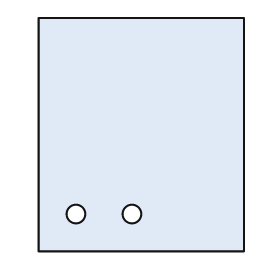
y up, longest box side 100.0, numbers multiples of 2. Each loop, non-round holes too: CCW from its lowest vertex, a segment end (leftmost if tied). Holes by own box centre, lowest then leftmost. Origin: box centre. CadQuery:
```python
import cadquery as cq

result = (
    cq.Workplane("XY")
    .moveTo(-44.0, -50.0)
    .lineTo(44.0, -50.0)
    .lineTo(44.0, 50.0)
    .lineTo(-44.0, 50.0)
    .close()
    .moveTo(-28.0, -34.0)
    .circle(4.0)
    .moveTo(-4.0, -34.0)
    .circle(4.0)
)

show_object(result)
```